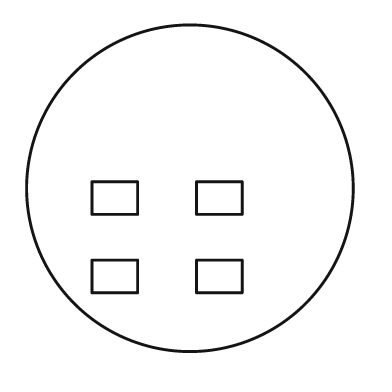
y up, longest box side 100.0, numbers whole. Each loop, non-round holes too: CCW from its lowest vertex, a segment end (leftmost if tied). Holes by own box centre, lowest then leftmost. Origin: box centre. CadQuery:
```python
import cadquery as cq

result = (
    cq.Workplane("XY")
    .moveTo(0.0, 0.0)
    .circle(50.0)
    .moveTo(-30.0, -32.0)
    .lineTo(-16.0, -32.0)
    .lineTo(-16.0, -22.0)
    .lineTo(-30.0, -22.0)
    .close()
    .moveTo(2.0, -32.0)
    .lineTo(16.0, -32.0)
    .lineTo(16.0, -22.0)
    .lineTo(2.0, -22.0)
    .close()
    .moveTo(-30.0, -8.0)
    .lineTo(-16.0, -8.0)
    .lineTo(-16.0, 2.0)
    .lineTo(-30.0, 2.0)
    .close()
    .moveTo(2.0, -8.0)
    .lineTo(16.0, -8.0)
    .lineTo(16.0, 2.0)
    .lineTo(2.0, 2.0)
    .close()
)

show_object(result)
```